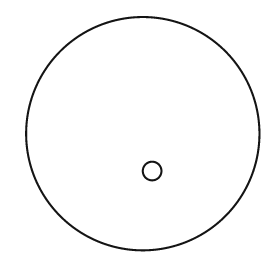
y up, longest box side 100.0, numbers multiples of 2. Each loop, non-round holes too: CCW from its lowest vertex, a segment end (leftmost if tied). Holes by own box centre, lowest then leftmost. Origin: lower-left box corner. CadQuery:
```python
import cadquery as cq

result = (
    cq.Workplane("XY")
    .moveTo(50.0, 50.0)
    .circle(50.0)
    .moveTo(54.0, 34.0)
    .circle(4.0)
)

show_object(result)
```